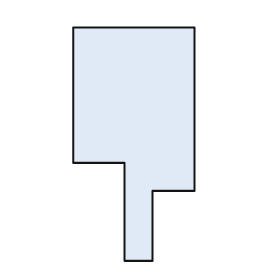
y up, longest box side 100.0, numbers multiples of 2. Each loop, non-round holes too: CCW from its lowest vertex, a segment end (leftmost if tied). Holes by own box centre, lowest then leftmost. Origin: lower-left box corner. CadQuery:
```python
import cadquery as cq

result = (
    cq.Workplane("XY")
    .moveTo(22.0, 0.0)
    .lineTo(34.0, 0.0)
    .lineTo(34.0, 30.0)
    .lineTo(52.0, 30.0)
    .lineTo(52.0, 100.0)
    .lineTo(0.0, 100.0)
    .lineTo(0.0, 42.0)
    .lineTo(22.0, 42.0)
    .close()
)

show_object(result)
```